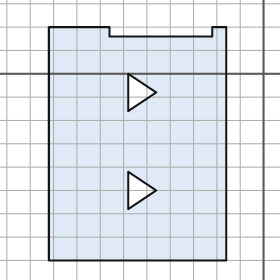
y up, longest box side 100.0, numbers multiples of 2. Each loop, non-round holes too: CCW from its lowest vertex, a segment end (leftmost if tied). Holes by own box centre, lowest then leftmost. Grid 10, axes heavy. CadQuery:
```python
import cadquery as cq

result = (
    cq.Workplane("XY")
    .moveTo(-92.0, -80.0)
    .lineTo(-16.0, -80.0)
    .lineTo(-16.0, 20.0)
    .lineTo(-22.0, 20.0)
    .lineTo(-22.0, 16.0)
    .lineTo(-66.0, 16.0)
    .lineTo(-66.0, 20.0)
    .lineTo(-92.0, 20.0)
    .close()
    .moveTo(-58.0, -58.0)
    .lineTo(-46.0, -50.0)
    .lineTo(-58.0, -42.0)
    .close()
    .moveTo(-58.0, -16.0)
    .lineTo(-46.0, -8.0)
    .lineTo(-58.0, 0.0)
    .close()
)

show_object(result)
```